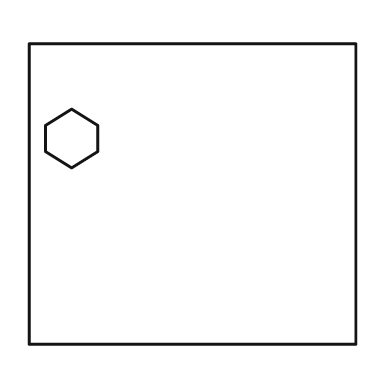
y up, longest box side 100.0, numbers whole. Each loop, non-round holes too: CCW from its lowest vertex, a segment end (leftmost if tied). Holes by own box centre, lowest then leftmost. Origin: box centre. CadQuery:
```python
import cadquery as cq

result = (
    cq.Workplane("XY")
    .moveTo(-50.0, -46.0)
    .lineTo(50.0, -46.0)
    .lineTo(50.0, 46.0)
    .lineTo(-50.0, 46.0)
    .close()
    .moveTo(-37.0, 8.0)
    .lineTo(-29.0, 13.0)
    .lineTo(-29.0, 21.0)
    .lineTo(-37.0, 26.0)
    .lineTo(-45.0, 21.0)
    .lineTo(-45.0, 13.0)
    .close()
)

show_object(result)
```